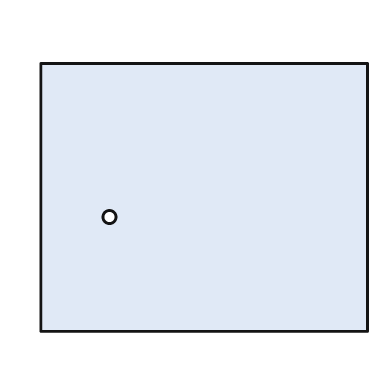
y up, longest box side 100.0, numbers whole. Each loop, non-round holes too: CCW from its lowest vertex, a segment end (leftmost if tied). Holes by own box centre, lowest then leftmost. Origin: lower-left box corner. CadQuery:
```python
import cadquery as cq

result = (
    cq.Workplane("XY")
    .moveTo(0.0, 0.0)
    .lineTo(100.0, 0.0)
    .lineTo(100.0, 82.0)
    .lineTo(0.0, 82.0)
    .close()
    .moveTo(21.0, 35.0)
    .circle(2.0)
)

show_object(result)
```